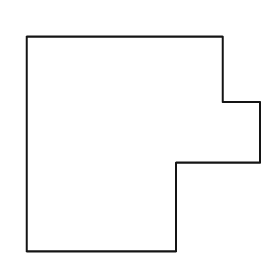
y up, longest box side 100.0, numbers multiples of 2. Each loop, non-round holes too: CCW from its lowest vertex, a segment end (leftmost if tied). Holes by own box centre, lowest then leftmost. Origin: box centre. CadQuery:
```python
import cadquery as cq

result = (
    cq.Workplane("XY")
    .moveTo(-50.0, -46.0)
    .lineTo(14.0, -46.0)
    .lineTo(14.0, -8.0)
    .lineTo(50.0, -8.0)
    .lineTo(50.0, 18.0)
    .lineTo(34.0, 18.0)
    .lineTo(34.0, 46.0)
    .lineTo(-50.0, 46.0)
    .close()
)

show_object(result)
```